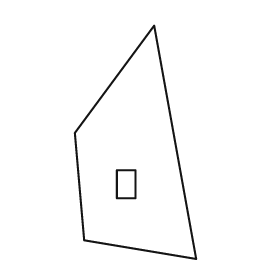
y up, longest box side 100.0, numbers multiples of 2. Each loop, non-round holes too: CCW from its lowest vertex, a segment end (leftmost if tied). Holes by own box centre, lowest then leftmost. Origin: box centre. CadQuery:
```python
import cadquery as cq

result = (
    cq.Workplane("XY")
    .moveTo(26.0, -50.0)
    .lineTo(8.0, 50.0)
    .lineTo(-26.0, 4.0)
    .lineTo(-22.0, -42.0)
    .close()
    .moveTo(-8.0, -24.0)
    .lineTo(0.0, -24.0)
    .lineTo(0.0, -12.0)
    .lineTo(-8.0, -12.0)
    .close()
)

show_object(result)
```